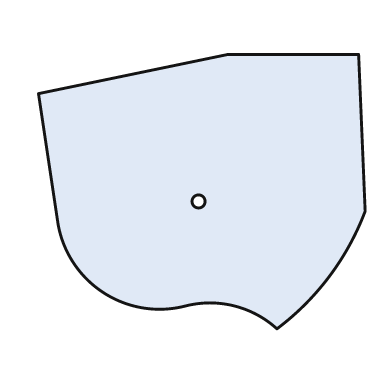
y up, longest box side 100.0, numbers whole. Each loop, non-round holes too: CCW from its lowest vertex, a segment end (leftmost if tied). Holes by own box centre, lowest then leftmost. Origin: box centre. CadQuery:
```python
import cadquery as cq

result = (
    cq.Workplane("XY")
    .moveTo(23.0, -42.0)
    .threePointArc((39.0, -26.0), (50.0, -6.0))
    .lineTo(48.0, 42.0)
    .lineTo(8.0, 42.0)
    .lineTo(-50.0, 30.0)
    .lineTo(-44.0, -10.0)
    .threePointArc((-30.0, -31.0), (-5.0, -35.0))
    .threePointArc((10.0, -35.0), (23.0, -42.0))
    .close()
    .moveTo(-1.0, -3.0)
    .circle(2.0)
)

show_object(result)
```